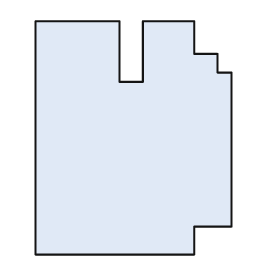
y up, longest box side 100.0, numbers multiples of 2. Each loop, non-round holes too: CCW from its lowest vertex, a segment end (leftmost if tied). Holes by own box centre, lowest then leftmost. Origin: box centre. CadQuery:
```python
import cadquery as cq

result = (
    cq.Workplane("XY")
    .moveTo(-42.0, -50.0)
    .lineTo(26.0, -50.0)
    .lineTo(26.0, -38.0)
    .lineTo(42.0, -38.0)
    .lineTo(42.0, 28.0)
    .lineTo(36.0, 28.0)
    .lineTo(36.0, 36.0)
    .lineTo(26.0, 36.0)
    .lineTo(26.0, 50.0)
    .lineTo(4.0, 50.0)
    .lineTo(4.0, 24.0)
    .lineTo(-6.0, 24.0)
    .lineTo(-6.0, 50.0)
    .lineTo(-42.0, 50.0)
    .close()
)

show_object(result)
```